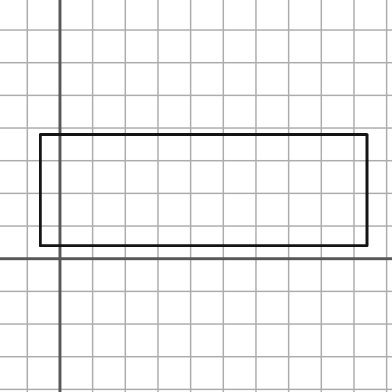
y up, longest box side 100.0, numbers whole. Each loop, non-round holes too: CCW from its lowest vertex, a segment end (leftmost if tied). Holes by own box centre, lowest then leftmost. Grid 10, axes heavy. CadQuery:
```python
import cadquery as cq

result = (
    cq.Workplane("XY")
    .moveTo(-6.0, 4.0)
    .lineTo(94.0, 4.0)
    .lineTo(94.0, 38.0)
    .lineTo(-6.0, 38.0)
    .close()
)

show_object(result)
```